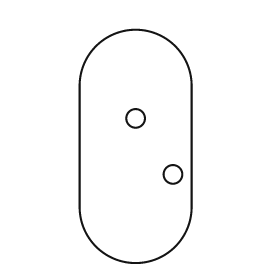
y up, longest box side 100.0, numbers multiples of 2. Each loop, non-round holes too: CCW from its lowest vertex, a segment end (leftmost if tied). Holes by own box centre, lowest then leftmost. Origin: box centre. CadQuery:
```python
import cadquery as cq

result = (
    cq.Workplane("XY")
    .moveTo(-24.0, -26.0)
    .threePointArc((0.0, -50.0), (24.0, -26.0))
    .lineTo(24.0, 26.0)
    .threePointArc((0.0, 50.0), (-24.0, 26.0))
    .close()
    .moveTo(16.0, -12.0)
    .circle(4.0)
    .moveTo(0.0, 12.0)
    .circle(4.0)
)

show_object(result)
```